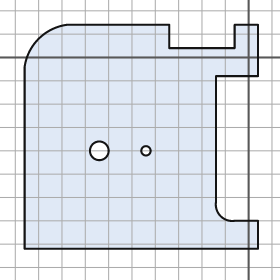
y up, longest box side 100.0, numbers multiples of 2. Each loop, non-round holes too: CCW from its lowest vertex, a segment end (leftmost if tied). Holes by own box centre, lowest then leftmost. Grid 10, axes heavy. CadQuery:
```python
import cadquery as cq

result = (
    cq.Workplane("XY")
    .moveTo(-96.0, -82.0)
    .lineTo(4.0, -82.0)
    .lineTo(4.0, -70.0)
    .lineTo(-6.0, -70.0)
    .threePointArc((-12.0, -68.0), (-14.0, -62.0))
    .lineTo(-14.0, -8.0)
    .lineTo(4.0, -8.0)
    .lineTo(4.0, 14.0)
    .lineTo(-6.0, 14.0)
    .lineTo(-6.0, 4.0)
    .lineTo(-34.0, 4.0)
    .lineTo(-34.0, 14.0)
    .lineTo(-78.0, 14.0)
    .threePointArc((-90.0, 8.0), (-96.0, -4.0))
    .close()
    .moveTo(-64.0, -40.0)
    .circle(4.0)
    .moveTo(-44.0, -40.0)
    .circle(2.0)
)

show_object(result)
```